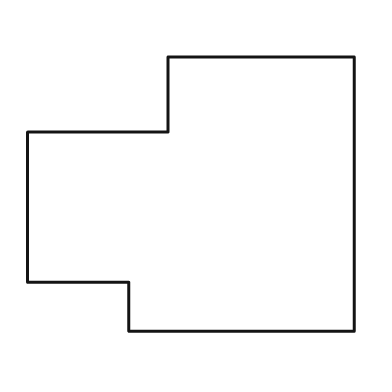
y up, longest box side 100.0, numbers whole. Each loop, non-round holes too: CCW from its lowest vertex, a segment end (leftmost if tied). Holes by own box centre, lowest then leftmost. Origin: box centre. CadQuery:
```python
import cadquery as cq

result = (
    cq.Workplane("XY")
    .moveTo(-19.0, -42.0)
    .lineTo(50.0, -42.0)
    .lineTo(50.0, 42.0)
    .lineTo(-7.0, 42.0)
    .lineTo(-7.0, 19.0)
    .lineTo(-50.0, 19.0)
    .lineTo(-50.0, -27.0)
    .lineTo(-19.0, -27.0)
    .close()
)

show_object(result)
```